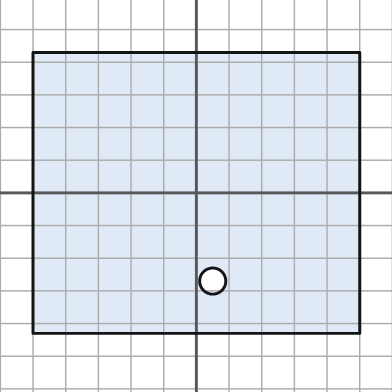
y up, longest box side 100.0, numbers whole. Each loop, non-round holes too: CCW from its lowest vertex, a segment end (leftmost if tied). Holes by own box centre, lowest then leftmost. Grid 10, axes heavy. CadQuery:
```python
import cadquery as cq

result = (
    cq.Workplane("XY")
    .moveTo(-50.0, -43.0)
    .lineTo(50.0, -43.0)
    .lineTo(50.0, 43.0)
    .lineTo(-50.0, 43.0)
    .close()
    .moveTo(5.0, -27.0)
    .circle(4.0)
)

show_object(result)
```